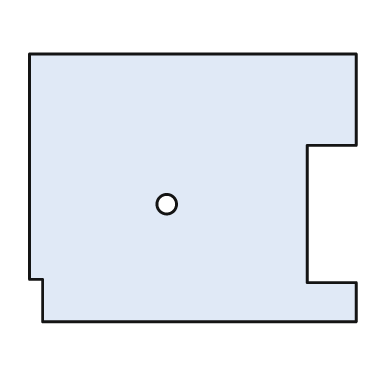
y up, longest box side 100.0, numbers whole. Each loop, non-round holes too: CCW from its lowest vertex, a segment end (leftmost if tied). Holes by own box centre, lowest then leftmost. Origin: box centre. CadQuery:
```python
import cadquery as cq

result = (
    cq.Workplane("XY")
    .moveTo(-46.0, -41.0)
    .lineTo(50.0, -41.0)
    .lineTo(50.0, -29.0)
    .lineTo(35.0, -29.0)
    .lineTo(35.0, 13.0)
    .lineTo(50.0, 13.0)
    .lineTo(50.0, 41.0)
    .lineTo(-50.0, 41.0)
    .lineTo(-50.0, -28.0)
    .lineTo(-46.0, -28.0)
    .close()
    .moveTo(-8.0, -5.0)
    .circle(3.0)
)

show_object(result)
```